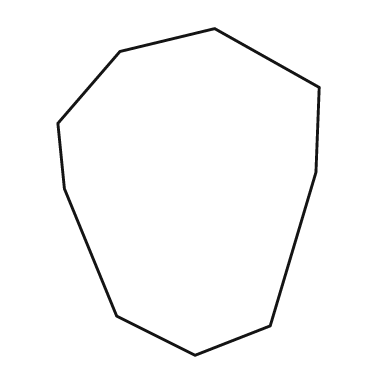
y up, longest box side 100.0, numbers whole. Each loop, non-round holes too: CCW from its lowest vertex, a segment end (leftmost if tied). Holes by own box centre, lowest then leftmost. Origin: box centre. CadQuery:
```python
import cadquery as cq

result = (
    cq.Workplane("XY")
    .moveTo(2.0, -50.0)
    .lineTo(25.0, -41.0)
    .lineTo(39.0, 6.0)
    .lineTo(40.0, 32.0)
    .lineTo(8.0, 50.0)
    .lineTo(-21.0, 43.0)
    .lineTo(-40.0, 21.0)
    .lineTo(-38.0, 1.0)
    .lineTo(-22.0, -38.0)
    .close()
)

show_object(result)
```